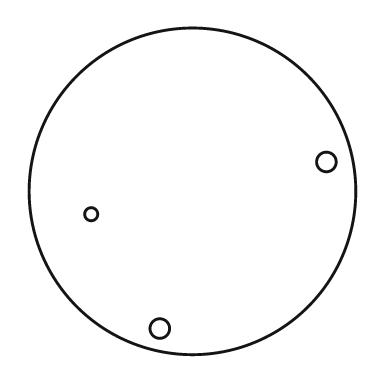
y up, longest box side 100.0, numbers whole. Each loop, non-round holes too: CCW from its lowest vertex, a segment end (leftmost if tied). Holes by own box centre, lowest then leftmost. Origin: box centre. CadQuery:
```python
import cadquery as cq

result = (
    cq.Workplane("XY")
    .moveTo(0.0, 0.0)
    .circle(50.0)
    .moveTo(-10.0, -42.0)
    .circle(3.0)
    .moveTo(-31.0, -7.0)
    .circle(2.0)
    .moveTo(41.0, 9.0)
    .circle(3.0)
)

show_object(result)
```